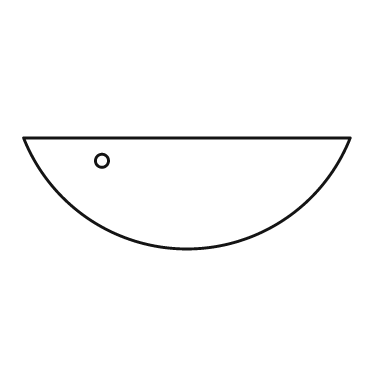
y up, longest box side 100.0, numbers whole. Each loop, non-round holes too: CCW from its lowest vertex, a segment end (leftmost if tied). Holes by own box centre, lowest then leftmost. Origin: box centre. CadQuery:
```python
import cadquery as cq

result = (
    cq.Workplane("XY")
    .moveTo(-50.0, 17.0)
    .threePointArc((0.0, -17.0), (50.0, 17.0))
    .close()
    .moveTo(-26.0, 10.0)
    .circle(2.0)
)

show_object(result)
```